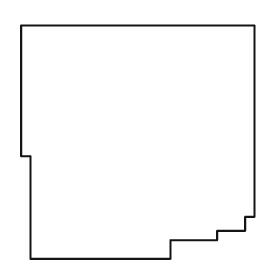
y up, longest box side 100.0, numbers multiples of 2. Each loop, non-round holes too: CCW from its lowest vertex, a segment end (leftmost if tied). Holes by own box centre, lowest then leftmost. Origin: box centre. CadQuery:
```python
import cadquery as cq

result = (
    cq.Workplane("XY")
    .moveTo(-46.0, -50.0)
    .lineTo(14.0, -50.0)
    .lineTo(14.0, -42.0)
    .lineTo(34.0, -42.0)
    .lineTo(34.0, -38.0)
    .lineTo(46.0, -38.0)
    .lineTo(46.0, -32.0)
    .lineTo(50.0, -32.0)
    .lineTo(50.0, 50.0)
    .lineTo(-50.0, 50.0)
    .lineTo(-50.0, -6.0)
    .lineTo(-46.0, -6.0)
    .close()
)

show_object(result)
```